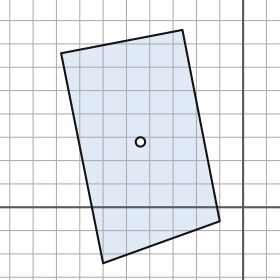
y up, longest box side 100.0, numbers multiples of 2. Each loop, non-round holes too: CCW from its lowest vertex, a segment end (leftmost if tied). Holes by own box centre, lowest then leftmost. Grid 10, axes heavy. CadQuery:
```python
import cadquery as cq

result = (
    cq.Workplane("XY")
    .moveTo(-60.0, -24.0)
    .lineTo(-10.0, -6.0)
    .lineTo(-26.0, 76.0)
    .lineTo(-78.0, 66.0)
    .close()
    .moveTo(-44.0, 28.0)
    .circle(2.0)
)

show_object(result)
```